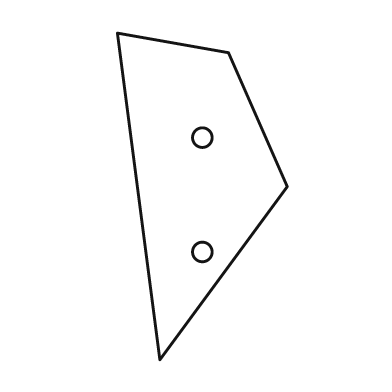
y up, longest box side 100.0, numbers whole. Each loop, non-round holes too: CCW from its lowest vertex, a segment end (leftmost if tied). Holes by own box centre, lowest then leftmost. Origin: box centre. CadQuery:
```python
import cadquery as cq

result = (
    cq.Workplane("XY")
    .moveTo(-13.0, -50.0)
    .lineTo(26.0, 3.0)
    .lineTo(8.0, 44.0)
    .lineTo(-26.0, 50.0)
    .close()
    .moveTo(0.0, -17.0)
    .circle(3.0)
    .moveTo(0.0, 18.0)
    .circle(3.0)
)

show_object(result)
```